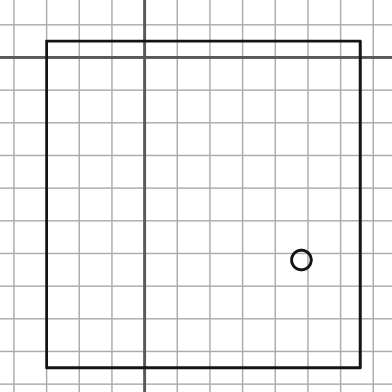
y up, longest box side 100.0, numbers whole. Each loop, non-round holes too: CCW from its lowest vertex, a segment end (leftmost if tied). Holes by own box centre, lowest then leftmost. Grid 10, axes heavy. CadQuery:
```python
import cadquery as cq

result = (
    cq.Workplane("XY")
    .moveTo(-30.0, -95.0)
    .lineTo(66.0, -95.0)
    .lineTo(66.0, 5.0)
    .lineTo(-30.0, 5.0)
    .close()
    .moveTo(48.0, -62.0)
    .circle(3.0)
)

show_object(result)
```